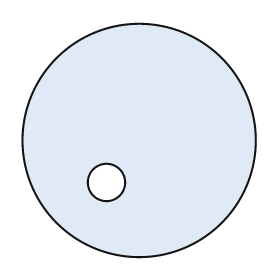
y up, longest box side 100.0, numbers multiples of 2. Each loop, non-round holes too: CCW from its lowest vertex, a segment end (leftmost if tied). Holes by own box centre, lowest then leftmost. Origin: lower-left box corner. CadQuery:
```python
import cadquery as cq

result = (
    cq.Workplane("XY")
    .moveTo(50.0, 50.0)
    .circle(50.0)
    .moveTo(36.0, 32.0)
    .circle(8.0)
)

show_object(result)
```